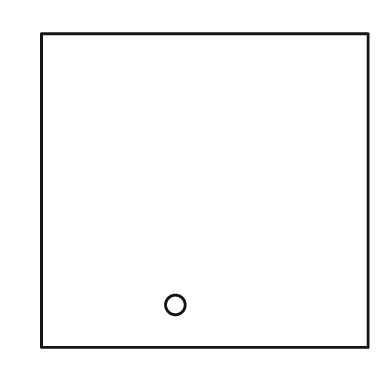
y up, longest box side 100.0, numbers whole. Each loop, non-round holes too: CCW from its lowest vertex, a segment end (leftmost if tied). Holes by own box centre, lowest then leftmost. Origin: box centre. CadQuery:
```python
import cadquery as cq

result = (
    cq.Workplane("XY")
    .moveTo(-50.0, -48.0)
    .lineTo(50.0, -48.0)
    .lineTo(50.0, 48.0)
    .lineTo(-50.0, 48.0)
    .close()
    .moveTo(-9.0, -35.0)
    .circle(3.0)
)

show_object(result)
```